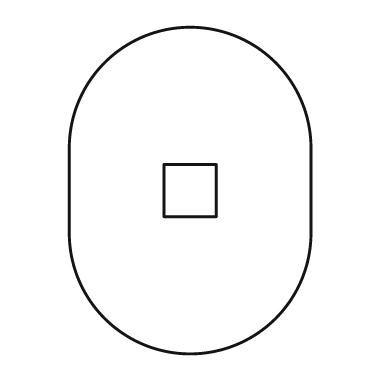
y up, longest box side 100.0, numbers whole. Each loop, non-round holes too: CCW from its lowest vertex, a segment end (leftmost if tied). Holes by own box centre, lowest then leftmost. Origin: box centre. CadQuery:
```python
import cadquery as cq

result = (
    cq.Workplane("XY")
    .moveTo(-37.0, -13.0)
    .threePointArc((0.0, -50.0), (37.0, -13.0))
    .lineTo(37.0, 13.0)
    .threePointArc((0.0, 50.0), (-37.0, 13.0))
    .close()
    .moveTo(-8.0, -8.0)
    .lineTo(8.0, -8.0)
    .lineTo(8.0, 8.0)
    .lineTo(-8.0, 8.0)
    .close()
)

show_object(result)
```